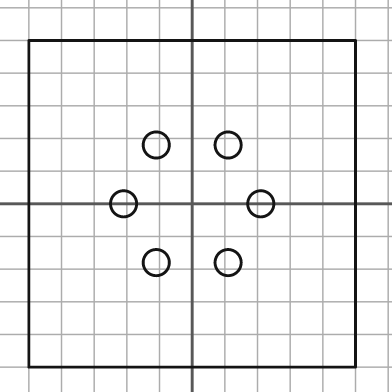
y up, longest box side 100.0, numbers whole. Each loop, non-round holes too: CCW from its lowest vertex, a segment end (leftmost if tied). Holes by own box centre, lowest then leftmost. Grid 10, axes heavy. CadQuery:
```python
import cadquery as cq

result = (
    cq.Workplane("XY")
    .moveTo(-50.0, -50.0)
    .lineTo(50.0, -50.0)
    .lineTo(50.0, 50.0)
    .lineTo(-50.0, 50.0)
    .close()
    .moveTo(-11.0, -18.0)
    .circle(4.0)
    .moveTo(11.0, -18.0)
    .circle(4.0)
    .moveTo(-21.0, 0.0)
    .circle(4.0)
    .moveTo(21.0, 0.0)
    .circle(4.0)
    .moveTo(-11.0, 18.0)
    .circle(4.0)
    .moveTo(11.0, 18.0)
    .circle(4.0)
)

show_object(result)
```